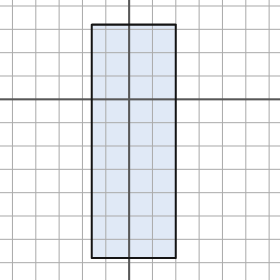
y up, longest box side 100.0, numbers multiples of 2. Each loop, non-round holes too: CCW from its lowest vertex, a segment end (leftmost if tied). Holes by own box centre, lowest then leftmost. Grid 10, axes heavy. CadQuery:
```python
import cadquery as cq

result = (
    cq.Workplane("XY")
    .moveTo(-16.0, -68.0)
    .lineTo(20.0, -68.0)
    .lineTo(20.0, 32.0)
    .lineTo(-16.0, 32.0)
    .close()
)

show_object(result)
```